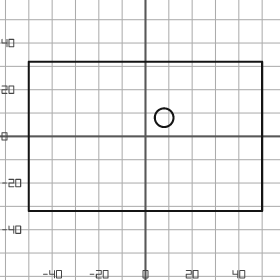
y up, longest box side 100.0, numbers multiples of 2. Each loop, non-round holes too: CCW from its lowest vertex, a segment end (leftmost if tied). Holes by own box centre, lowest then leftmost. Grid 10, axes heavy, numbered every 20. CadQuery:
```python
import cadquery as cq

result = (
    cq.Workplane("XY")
    .moveTo(-50.0, -32.0)
    .lineTo(50.0, -32.0)
    .lineTo(50.0, 32.0)
    .lineTo(-50.0, 32.0)
    .close()
    .moveTo(8.0, 8.0)
    .circle(4.0)
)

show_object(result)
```